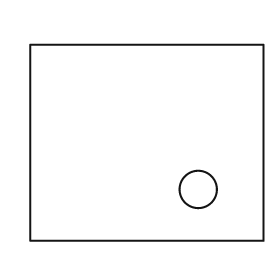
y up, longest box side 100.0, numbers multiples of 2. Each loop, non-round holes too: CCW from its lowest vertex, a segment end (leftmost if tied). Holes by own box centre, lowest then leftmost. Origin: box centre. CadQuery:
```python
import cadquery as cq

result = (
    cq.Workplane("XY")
    .moveTo(-50.0, -42.0)
    .lineTo(50.0, -42.0)
    .lineTo(50.0, 42.0)
    .lineTo(-50.0, 42.0)
    .close()
    .moveTo(22.0, -20.0)
    .circle(8.0)
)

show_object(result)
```